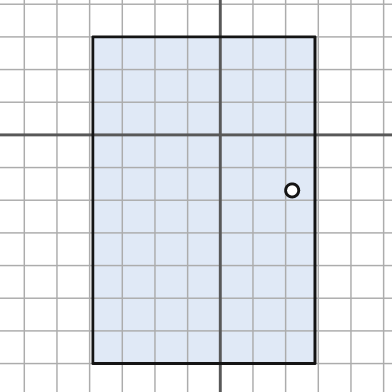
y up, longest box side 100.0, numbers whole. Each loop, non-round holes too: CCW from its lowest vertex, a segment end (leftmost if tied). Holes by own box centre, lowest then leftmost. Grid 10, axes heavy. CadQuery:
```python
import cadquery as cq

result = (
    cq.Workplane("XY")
    .moveTo(-39.0, -70.0)
    .lineTo(29.0, -70.0)
    .lineTo(29.0, 30.0)
    .lineTo(-39.0, 30.0)
    .close()
    .moveTo(22.0, -17.0)
    .circle(2.0)
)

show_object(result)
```